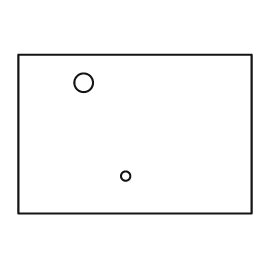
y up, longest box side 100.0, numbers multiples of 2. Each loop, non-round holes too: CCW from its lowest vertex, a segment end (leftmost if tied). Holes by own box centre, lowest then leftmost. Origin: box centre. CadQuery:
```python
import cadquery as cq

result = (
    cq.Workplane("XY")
    .moveTo(-50.0, -34.0)
    .lineTo(50.0, -34.0)
    .lineTo(50.0, 34.0)
    .lineTo(-50.0, 34.0)
    .close()
    .moveTo(-4.0, -18.0)
    .circle(2.0)
    .moveTo(-22.0, 22.0)
    .circle(4.0)
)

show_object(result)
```